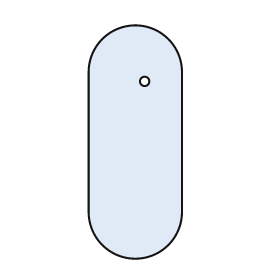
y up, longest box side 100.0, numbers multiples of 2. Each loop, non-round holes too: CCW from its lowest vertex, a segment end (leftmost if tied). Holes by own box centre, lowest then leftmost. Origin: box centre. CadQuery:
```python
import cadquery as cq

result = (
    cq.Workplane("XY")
    .moveTo(-20.0, -30.0)
    .threePointArc((0.0, -50.0), (20.0, -30.0))
    .lineTo(20.0, 30.0)
    .threePointArc((0.0, 50.0), (-20.0, 30.0))
    .close()
    .moveTo(4.0, 26.0)
    .circle(2.0)
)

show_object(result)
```